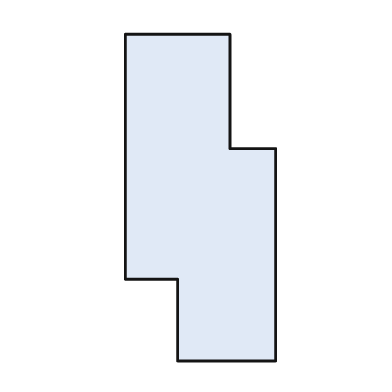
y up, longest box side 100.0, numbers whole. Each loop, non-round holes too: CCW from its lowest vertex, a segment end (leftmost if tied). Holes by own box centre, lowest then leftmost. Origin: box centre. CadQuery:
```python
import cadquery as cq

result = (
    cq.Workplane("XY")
    .moveTo(-7.0, -50.0)
    .lineTo(23.0, -50.0)
    .lineTo(23.0, 15.0)
    .lineTo(9.0, 15.0)
    .lineTo(9.0, 50.0)
    .lineTo(-23.0, 50.0)
    .lineTo(-23.0, -25.0)
    .lineTo(-7.0, -25.0)
    .close()
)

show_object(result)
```